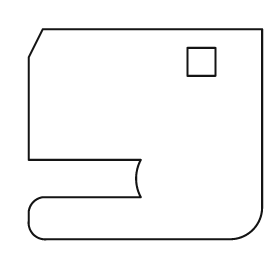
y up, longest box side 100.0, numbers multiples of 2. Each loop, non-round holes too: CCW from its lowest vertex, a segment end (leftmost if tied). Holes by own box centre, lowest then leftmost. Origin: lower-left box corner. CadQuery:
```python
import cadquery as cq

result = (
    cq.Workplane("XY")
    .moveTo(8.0, 0.0)
    .lineTo(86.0, 0.0)
    .threePointArc((96.0, 4.0), (100.0, 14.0))
    .lineTo(100.0, 90.0)
    .lineTo(6.0, 90.0)
    .lineTo(0.0, 78.0)
    .lineTo(0.0, 34.0)
    .lineTo(48.0, 34.0)
    .threePointArc((46.0, 26.0), (48.0, 18.0))
    .lineTo(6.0, 18.0)
    .threePointArc((2.0, 16.0), (0.0, 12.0))
    .lineTo(0.0, 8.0)
    .threePointArc((2.0, 2.0), (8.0, 0.0))
    .close()
    .moveTo(68.0, 70.0)
    .lineTo(80.0, 70.0)
    .lineTo(80.0, 82.0)
    .lineTo(68.0, 82.0)
    .close()
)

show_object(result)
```